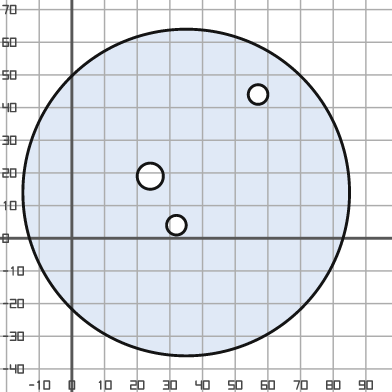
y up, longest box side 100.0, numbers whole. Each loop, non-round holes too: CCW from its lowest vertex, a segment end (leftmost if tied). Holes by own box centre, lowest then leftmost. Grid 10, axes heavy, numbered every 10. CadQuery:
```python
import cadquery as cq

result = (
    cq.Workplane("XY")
    .moveTo(35.0, 14.0)
    .circle(50.0)
    .moveTo(32.0, 4.0)
    .circle(3.0)
    .moveTo(24.0, 19.0)
    .circle(4.0)
    .moveTo(57.0, 44.0)
    .circle(3.0)
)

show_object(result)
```